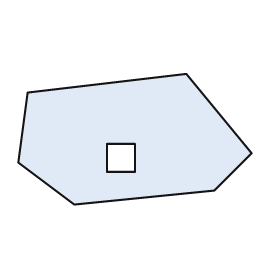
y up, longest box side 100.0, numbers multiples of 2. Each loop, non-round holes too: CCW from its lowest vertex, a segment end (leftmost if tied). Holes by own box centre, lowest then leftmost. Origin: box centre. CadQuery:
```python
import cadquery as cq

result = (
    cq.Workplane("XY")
    .moveTo(-26.0, -28.0)
    .lineTo(34.0, -22.0)
    .lineTo(50.0, -6.0)
    .lineTo(22.0, 28.0)
    .lineTo(-46.0, 20.0)
    .lineTo(-50.0, -10.0)
    .close()
    .moveTo(-12.0, -14.0)
    .lineTo(0.0, -14.0)
    .lineTo(0.0, -2.0)
    .lineTo(-12.0, -2.0)
    .close()
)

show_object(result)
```